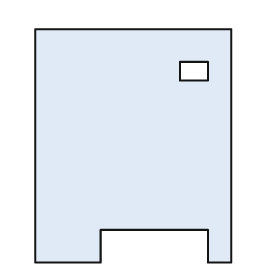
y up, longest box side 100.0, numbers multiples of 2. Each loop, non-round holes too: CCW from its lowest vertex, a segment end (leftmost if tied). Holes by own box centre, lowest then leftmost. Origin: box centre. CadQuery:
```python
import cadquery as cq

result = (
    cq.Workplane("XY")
    .moveTo(-42.0, -50.0)
    .lineTo(-14.0, -50.0)
    .lineTo(-14.0, -36.0)
    .lineTo(32.0, -36.0)
    .lineTo(32.0, -50.0)
    .lineTo(42.0, -50.0)
    .lineTo(42.0, 50.0)
    .lineTo(-42.0, 50.0)
    .close()
    .moveTo(20.0, 28.0)
    .lineTo(32.0, 28.0)
    .lineTo(32.0, 36.0)
    .lineTo(20.0, 36.0)
    .close()
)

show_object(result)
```